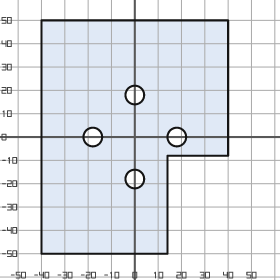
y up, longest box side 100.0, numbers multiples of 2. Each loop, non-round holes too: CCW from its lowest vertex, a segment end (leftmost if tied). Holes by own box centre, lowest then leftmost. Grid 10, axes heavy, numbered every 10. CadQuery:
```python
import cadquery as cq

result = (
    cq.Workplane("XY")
    .moveTo(-40.0, -50.0)
    .lineTo(14.0, -50.0)
    .lineTo(14.0, -8.0)
    .lineTo(40.0, -8.0)
    .lineTo(40.0, 50.0)
    .lineTo(-40.0, 50.0)
    .close()
    .moveTo(0.0, -18.0)
    .circle(4.0)
    .moveTo(-18.0, 0.0)
    .circle(4.0)
    .moveTo(18.0, 0.0)
    .circle(4.0)
    .moveTo(0.0, 18.0)
    .circle(4.0)
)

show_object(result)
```